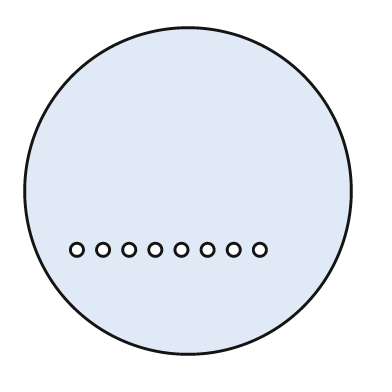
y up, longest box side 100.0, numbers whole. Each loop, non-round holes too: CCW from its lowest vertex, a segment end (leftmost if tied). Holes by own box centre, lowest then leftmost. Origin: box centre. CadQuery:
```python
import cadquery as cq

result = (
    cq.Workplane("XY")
    .moveTo(0.0, 0.0)
    .circle(50.0)
    .moveTo(-34.0, -18.0)
    .circle(2.0)
    .moveTo(-26.0, -18.0)
    .circle(2.0)
    .moveTo(-18.0, -18.0)
    .circle(2.0)
    .moveTo(-10.0, -18.0)
    .circle(2.0)
    .moveTo(-2.0, -18.0)
    .circle(2.0)
    .moveTo(6.0, -18.0)
    .circle(2.0)
    .moveTo(14.0, -18.0)
    .circle(2.0)
    .moveTo(22.0, -18.0)
    .circle(2.0)
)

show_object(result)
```